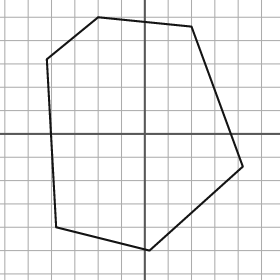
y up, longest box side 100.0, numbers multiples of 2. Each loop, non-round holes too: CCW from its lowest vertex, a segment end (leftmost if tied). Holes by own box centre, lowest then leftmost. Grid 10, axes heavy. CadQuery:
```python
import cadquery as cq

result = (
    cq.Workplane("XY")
    .moveTo(2.0, -50.0)
    .lineTo(42.0, -14.0)
    .lineTo(20.0, 46.0)
    .lineTo(-20.0, 50.0)
    .lineTo(-42.0, 32.0)
    .lineTo(-38.0, -40.0)
    .close()
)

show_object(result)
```